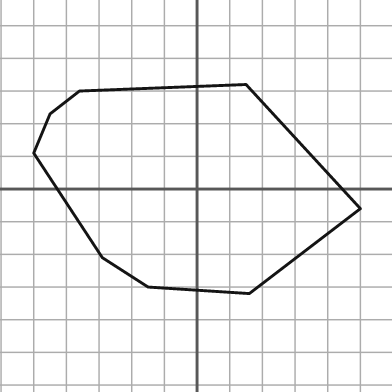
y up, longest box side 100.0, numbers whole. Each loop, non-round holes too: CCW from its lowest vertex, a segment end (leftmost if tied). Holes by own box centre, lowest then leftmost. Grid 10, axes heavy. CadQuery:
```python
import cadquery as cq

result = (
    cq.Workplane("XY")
    .moveTo(16.0, -32.0)
    .lineTo(50.0, -6.0)
    .lineTo(15.0, 32.0)
    .lineTo(-36.0, 30.0)
    .lineTo(-45.0, 23.0)
    .lineTo(-50.0, 11.0)
    .lineTo(-29.0, -21.0)
    .lineTo(-15.0, -30.0)
    .close()
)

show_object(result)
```